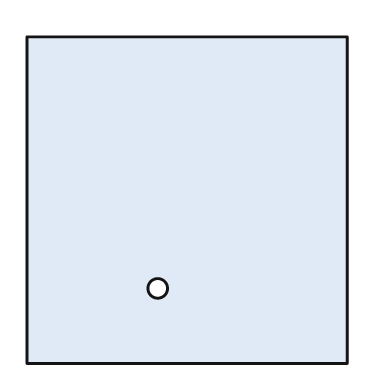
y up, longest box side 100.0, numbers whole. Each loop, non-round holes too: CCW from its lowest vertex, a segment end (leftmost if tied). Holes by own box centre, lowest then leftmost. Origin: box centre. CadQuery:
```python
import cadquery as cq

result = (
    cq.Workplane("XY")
    .moveTo(-49.0, -50.0)
    .lineTo(49.0, -50.0)
    .lineTo(49.0, 50.0)
    .lineTo(-49.0, 50.0)
    .close()
    .moveTo(-9.0, -27.0)
    .circle(3.0)
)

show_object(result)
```